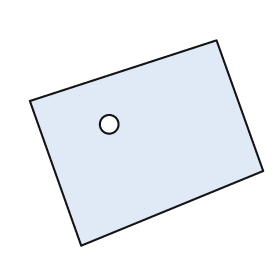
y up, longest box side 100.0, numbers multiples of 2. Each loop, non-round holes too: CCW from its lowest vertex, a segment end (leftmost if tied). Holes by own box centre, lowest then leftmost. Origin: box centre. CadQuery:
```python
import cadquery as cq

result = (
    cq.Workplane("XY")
    .moveTo(-28.0, -44.0)
    .lineTo(50.0, -12.0)
    .lineTo(30.0, 44.0)
    .lineTo(-50.0, 18.0)
    .close()
    .moveTo(-16.0, 8.0)
    .circle(4.0)
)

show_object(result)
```